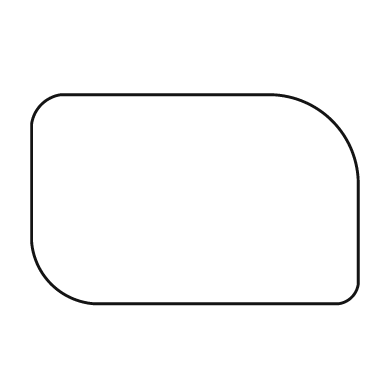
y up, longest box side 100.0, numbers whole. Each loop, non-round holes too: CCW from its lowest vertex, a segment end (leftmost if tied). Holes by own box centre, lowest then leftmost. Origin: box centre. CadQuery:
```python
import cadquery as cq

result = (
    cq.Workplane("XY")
    .moveTo(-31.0, -32.0)
    .lineTo(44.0, -32.0)
    .threePointArc((48.0, -30.0), (50.0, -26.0))
    .lineTo(50.0, 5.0)
    .threePointArc((42.0, 24.0), (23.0, 32.0))
    .lineTo(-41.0, 32.0)
    .threePointArc((-47.0, 29.0), (-50.0, 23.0))
    .lineTo(-50.0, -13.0)
    .threePointArc((-44.0, -26.0), (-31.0, -32.0))
    .close()
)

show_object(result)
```